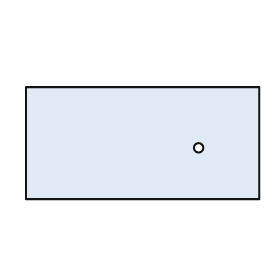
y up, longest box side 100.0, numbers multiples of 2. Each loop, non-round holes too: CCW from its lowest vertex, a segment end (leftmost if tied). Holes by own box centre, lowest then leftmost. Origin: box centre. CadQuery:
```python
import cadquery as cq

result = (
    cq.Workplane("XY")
    .moveTo(-50.0, -24.0)
    .lineTo(50.0, -24.0)
    .lineTo(50.0, 24.0)
    .lineTo(-50.0, 24.0)
    .close()
    .moveTo(24.0, -2.0)
    .circle(2.0)
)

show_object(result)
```